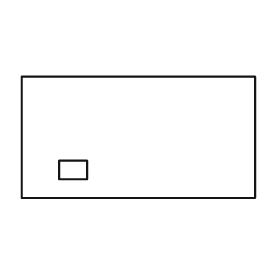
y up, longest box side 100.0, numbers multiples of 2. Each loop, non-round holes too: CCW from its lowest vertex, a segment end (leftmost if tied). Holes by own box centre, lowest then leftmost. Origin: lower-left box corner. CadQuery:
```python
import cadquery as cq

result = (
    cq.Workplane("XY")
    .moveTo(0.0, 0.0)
    .lineTo(100.0, 0.0)
    .lineTo(100.0, 52.0)
    .lineTo(0.0, 52.0)
    .close()
    .moveTo(16.0, 8.0)
    .lineTo(28.0, 8.0)
    .lineTo(28.0, 16.0)
    .lineTo(16.0, 16.0)
    .close()
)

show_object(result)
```